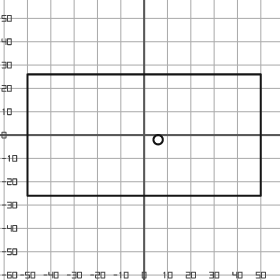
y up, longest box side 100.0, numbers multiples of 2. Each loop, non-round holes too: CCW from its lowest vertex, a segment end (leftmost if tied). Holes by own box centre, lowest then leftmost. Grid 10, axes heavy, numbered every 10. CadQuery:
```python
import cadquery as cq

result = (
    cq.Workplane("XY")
    .moveTo(-50.0, -26.0)
    .lineTo(50.0, -26.0)
    .lineTo(50.0, 26.0)
    .lineTo(-50.0, 26.0)
    .close()
    .moveTo(6.0, -2.0)
    .circle(2.0)
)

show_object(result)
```